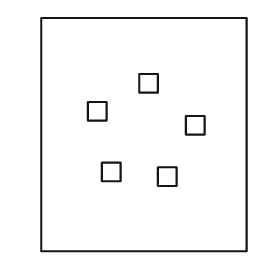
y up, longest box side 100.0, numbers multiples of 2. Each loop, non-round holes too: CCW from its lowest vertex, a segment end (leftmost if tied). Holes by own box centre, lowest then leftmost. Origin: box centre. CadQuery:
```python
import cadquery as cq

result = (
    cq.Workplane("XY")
    .moveTo(-44.0, -50.0)
    .lineTo(44.0, -50.0)
    .lineTo(44.0, 50.0)
    .lineTo(-44.0, 50.0)
    .close()
    .moveTo(6.0, -22.0)
    .lineTo(14.0, -22.0)
    .lineTo(14.0, -14.0)
    .lineTo(6.0, -14.0)
    .close()
    .moveTo(-18.0, -20.0)
    .lineTo(-10.0, -20.0)
    .lineTo(-10.0, -12.0)
    .lineTo(-18.0, -12.0)
    .close()
    .moveTo(18.0, 0.0)
    .lineTo(26.0, 0.0)
    .lineTo(26.0, 8.0)
    .lineTo(18.0, 8.0)
    .close()
    .moveTo(-24.0, 6.0)
    .lineTo(-16.0, 6.0)
    .lineTo(-16.0, 14.0)
    .lineTo(-24.0, 14.0)
    .close()
    .moveTo(-2.0, 18.0)
    .lineTo(6.0, 18.0)
    .lineTo(6.0, 26.0)
    .lineTo(-2.0, 26.0)
    .close()
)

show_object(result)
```